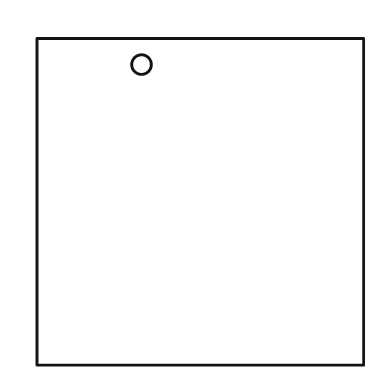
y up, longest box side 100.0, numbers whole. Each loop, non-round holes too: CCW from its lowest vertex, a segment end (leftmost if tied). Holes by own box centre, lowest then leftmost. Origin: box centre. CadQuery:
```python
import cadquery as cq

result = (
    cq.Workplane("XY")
    .moveTo(-50.0, -50.0)
    .lineTo(50.0, -50.0)
    .lineTo(50.0, 50.0)
    .lineTo(-50.0, 50.0)
    .close()
    .moveTo(-18.0, 42.0)
    .circle(3.0)
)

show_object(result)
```